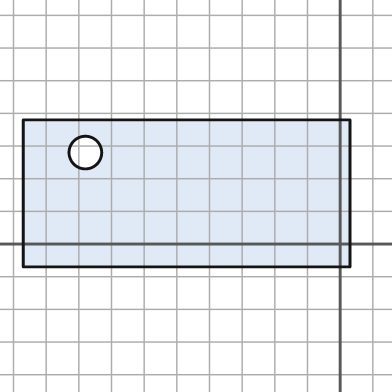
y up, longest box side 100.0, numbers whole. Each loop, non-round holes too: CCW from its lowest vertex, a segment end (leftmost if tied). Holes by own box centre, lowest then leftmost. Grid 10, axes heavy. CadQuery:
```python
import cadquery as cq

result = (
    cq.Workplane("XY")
    .moveTo(-97.0, -7.0)
    .lineTo(3.0, -7.0)
    .lineTo(3.0, 38.0)
    .lineTo(-97.0, 38.0)
    .close()
    .moveTo(-78.0, 28.0)
    .circle(5.0)
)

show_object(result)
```